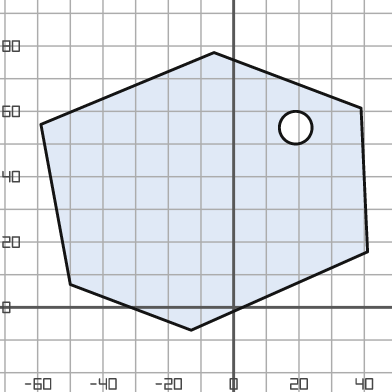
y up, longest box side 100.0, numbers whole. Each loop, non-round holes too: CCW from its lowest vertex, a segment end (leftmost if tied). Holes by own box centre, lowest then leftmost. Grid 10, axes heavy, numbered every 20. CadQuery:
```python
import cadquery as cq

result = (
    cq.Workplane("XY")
    .moveTo(-13.0, -7.0)
    .lineTo(41.0, 17.0)
    .lineTo(39.0, 61.0)
    .lineTo(-6.0, 78.0)
    .lineTo(-59.0, 56.0)
    .lineTo(-50.0, 7.0)
    .close()
    .moveTo(19.0, 55.0)
    .circle(5.0)
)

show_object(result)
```